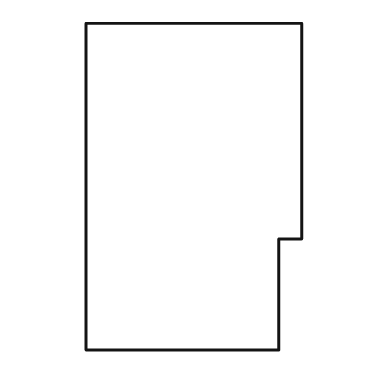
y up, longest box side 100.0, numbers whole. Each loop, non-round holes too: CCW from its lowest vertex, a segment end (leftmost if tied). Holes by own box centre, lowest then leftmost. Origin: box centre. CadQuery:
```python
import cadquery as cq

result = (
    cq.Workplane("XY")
    .moveTo(-33.0, -50.0)
    .lineTo(26.0, -50.0)
    .lineTo(26.0, -16.0)
    .lineTo(33.0, -16.0)
    .lineTo(33.0, 50.0)
    .lineTo(-33.0, 50.0)
    .close()
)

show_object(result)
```